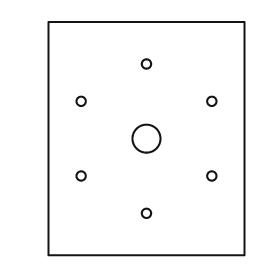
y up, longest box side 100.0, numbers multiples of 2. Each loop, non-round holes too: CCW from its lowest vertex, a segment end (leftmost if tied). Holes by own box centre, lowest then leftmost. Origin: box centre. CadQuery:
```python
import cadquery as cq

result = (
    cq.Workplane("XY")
    .moveTo(-42.0, -50.0)
    .lineTo(42.0, -50.0)
    .lineTo(42.0, 50.0)
    .lineTo(-42.0, 50.0)
    .close()
    .moveTo(0.0, -32.0)
    .circle(2.0)
    .moveTo(-28.0, -16.0)
    .circle(2.0)
    .moveTo(28.0, -16.0)
    .circle(2.0)
    .moveTo(0.0, 0.0)
    .circle(6.0)
    .moveTo(-28.0, 16.0)
    .circle(2.0)
    .moveTo(28.0, 16.0)
    .circle(2.0)
    .moveTo(0.0, 32.0)
    .circle(2.0)
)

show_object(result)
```